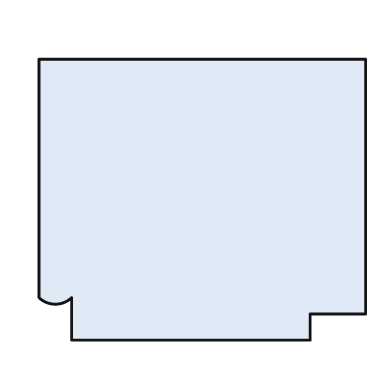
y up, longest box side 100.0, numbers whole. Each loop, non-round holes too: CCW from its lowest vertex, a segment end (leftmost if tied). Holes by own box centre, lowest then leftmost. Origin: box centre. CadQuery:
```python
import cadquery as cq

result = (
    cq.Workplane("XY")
    .moveTo(-40.0, -43.0)
    .lineTo(33.0, -43.0)
    .lineTo(33.0, -35.0)
    .lineTo(50.0, -35.0)
    .lineTo(50.0, 43.0)
    .lineTo(-50.0, 43.0)
    .lineTo(-50.0, -30.0)
    .threePointArc((-45.0, -32.0), (-40.0, -30.0))
    .close()
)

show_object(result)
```